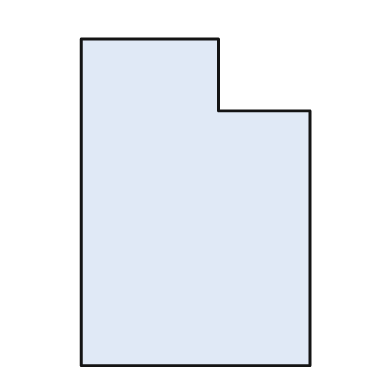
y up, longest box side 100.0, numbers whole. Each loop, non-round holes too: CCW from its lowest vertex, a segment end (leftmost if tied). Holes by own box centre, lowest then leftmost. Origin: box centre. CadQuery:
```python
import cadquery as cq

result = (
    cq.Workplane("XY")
    .moveTo(-35.0, -50.0)
    .lineTo(35.0, -50.0)
    .lineTo(35.0, 28.0)
    .lineTo(7.0, 28.0)
    .lineTo(7.0, 50.0)
    .lineTo(-35.0, 50.0)
    .close()
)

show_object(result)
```